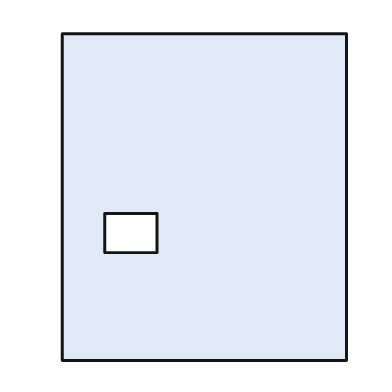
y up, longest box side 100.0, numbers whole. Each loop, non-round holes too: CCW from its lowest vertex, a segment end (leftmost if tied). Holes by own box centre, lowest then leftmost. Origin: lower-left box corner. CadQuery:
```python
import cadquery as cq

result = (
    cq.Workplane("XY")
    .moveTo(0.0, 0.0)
    .lineTo(87.0, 0.0)
    .lineTo(87.0, 100.0)
    .lineTo(0.0, 100.0)
    .close()
    .moveTo(13.0, 33.0)
    .lineTo(29.0, 33.0)
    .lineTo(29.0, 45.0)
    .lineTo(13.0, 45.0)
    .close()
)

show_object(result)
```